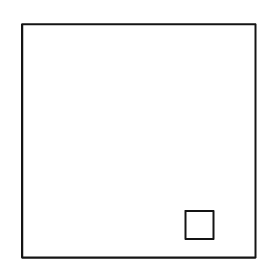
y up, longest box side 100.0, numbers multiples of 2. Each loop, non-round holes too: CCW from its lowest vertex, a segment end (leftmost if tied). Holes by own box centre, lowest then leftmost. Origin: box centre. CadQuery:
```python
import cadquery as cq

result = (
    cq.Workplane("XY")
    .moveTo(-50.0, -50.0)
    .lineTo(50.0, -50.0)
    .lineTo(50.0, 50.0)
    .lineTo(-50.0, 50.0)
    .close()
    .moveTo(20.0, -42.0)
    .lineTo(32.0, -42.0)
    .lineTo(32.0, -30.0)
    .lineTo(20.0, -30.0)
    .close()
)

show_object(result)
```